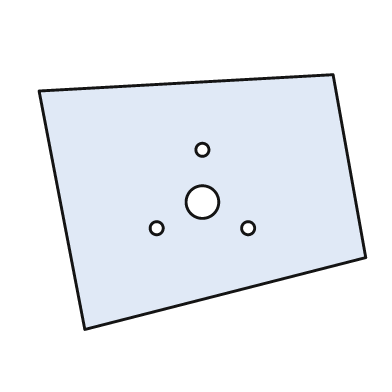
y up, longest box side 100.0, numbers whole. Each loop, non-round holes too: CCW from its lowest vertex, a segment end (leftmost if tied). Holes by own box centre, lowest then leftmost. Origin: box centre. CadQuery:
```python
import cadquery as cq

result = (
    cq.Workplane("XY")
    .moveTo(-36.0, -39.0)
    .lineTo(50.0, -17.0)
    .lineTo(40.0, 39.0)
    .lineTo(-50.0, 34.0)
    .close()
    .moveTo(-14.0, -8.0)
    .circle(2.0)
    .moveTo(14.0, -8.0)
    .circle(2.0)
    .moveTo(0.0, 0.0)
    .circle(5.0)
    .moveTo(0.0, 16.0)
    .circle(2.0)
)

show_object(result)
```